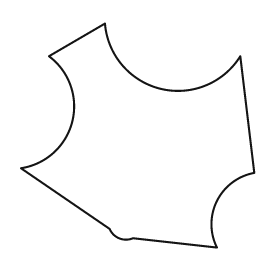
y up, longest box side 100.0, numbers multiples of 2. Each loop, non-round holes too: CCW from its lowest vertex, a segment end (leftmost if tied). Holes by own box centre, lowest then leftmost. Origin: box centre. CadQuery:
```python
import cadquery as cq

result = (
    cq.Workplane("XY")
    .moveTo(34.0, -48.0)
    .threePointArc((34.0, -28.0), (50.0, -16.0))
    .lineTo(44.0, 34.0)
    .threePointArc((10.0, 20.0), (-14.0, 48.0))
    .lineTo(-38.0, 34.0)
    .threePointArc((-28.0, 6.0), (-50.0, -14.0))
    .lineTo(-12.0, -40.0)
    .threePointArc((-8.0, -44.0), (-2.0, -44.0))
    .close()
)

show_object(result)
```